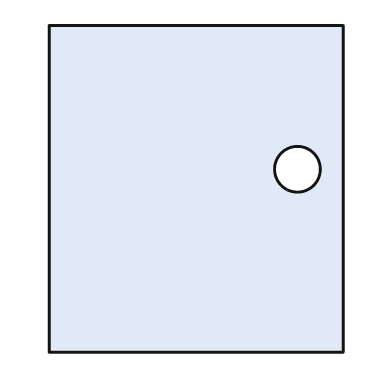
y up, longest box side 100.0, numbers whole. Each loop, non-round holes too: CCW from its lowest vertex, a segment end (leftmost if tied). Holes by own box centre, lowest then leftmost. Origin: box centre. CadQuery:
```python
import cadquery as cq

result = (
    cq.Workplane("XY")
    .moveTo(-45.0, -50.0)
    .lineTo(45.0, -50.0)
    .lineTo(45.0, 50.0)
    .lineTo(-45.0, 50.0)
    .close()
    .moveTo(31.0, 6.0)
    .circle(7.0)
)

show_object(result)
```